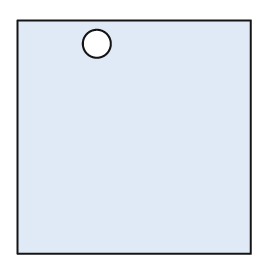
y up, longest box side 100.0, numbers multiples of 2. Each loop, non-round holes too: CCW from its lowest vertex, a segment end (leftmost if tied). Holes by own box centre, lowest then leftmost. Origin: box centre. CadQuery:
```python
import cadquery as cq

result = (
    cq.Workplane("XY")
    .moveTo(-50.0, -50.0)
    .lineTo(50.0, -50.0)
    .lineTo(50.0, 50.0)
    .lineTo(-50.0, 50.0)
    .close()
    .moveTo(-16.0, 40.0)
    .circle(6.0)
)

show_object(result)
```